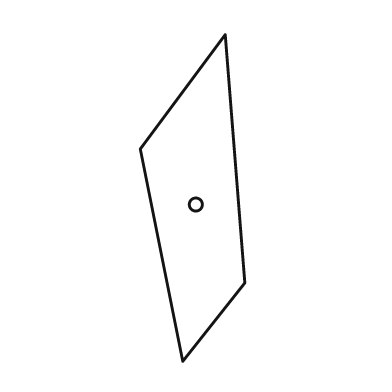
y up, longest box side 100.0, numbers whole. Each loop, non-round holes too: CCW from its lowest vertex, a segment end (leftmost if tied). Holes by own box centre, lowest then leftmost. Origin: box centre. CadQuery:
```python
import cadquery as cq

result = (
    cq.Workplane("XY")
    .moveTo(-3.0, -50.0)
    .lineTo(16.0, -26.0)
    .lineTo(10.0, 50.0)
    .lineTo(-16.0, 15.0)
    .close()
    .moveTo(1.0, -2.0)
    .circle(2.0)
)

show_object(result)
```